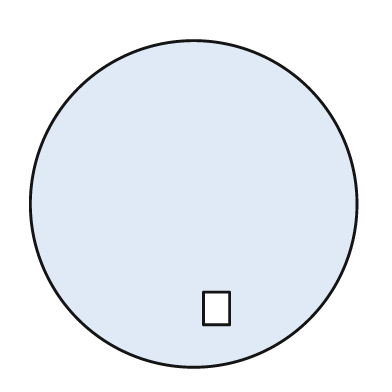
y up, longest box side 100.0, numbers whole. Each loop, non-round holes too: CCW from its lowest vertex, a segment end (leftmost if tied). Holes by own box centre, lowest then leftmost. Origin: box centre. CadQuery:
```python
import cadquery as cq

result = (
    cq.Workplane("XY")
    .moveTo(0.0, 0.0)
    .circle(50.0)
    .moveTo(3.0, -37.0)
    .lineTo(11.0, -37.0)
    .lineTo(11.0, -27.0)
    .lineTo(3.0, -27.0)
    .close()
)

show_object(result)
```